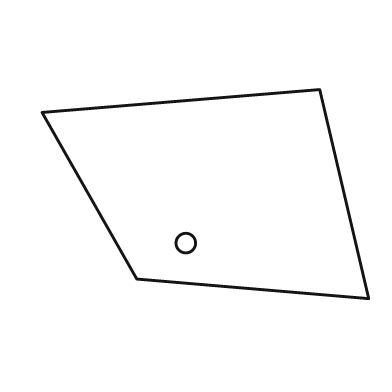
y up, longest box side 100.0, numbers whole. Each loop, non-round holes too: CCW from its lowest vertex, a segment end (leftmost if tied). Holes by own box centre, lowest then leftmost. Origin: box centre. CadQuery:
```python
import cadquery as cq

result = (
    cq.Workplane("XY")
    .moveTo(50.0, -32.0)
    .lineTo(35.0, 32.0)
    .lineTo(-50.0, 25.0)
    .lineTo(-21.0, -26.0)
    .close()
    .moveTo(-6.0, -15.0)
    .circle(3.0)
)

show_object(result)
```